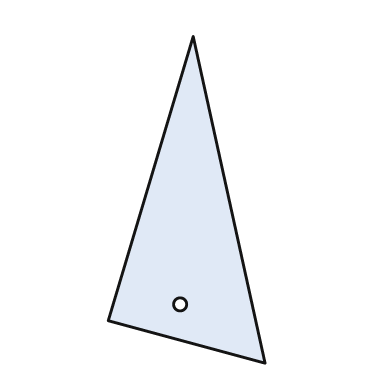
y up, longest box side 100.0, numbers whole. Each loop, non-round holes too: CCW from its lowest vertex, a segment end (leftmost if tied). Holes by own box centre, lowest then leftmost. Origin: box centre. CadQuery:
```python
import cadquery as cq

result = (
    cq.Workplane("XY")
    .moveTo(24.0, -50.0)
    .lineTo(2.0, 50.0)
    .lineTo(-24.0, -37.0)
    .close()
    .moveTo(-2.0, -32.0)
    .circle(2.0)
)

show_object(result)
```